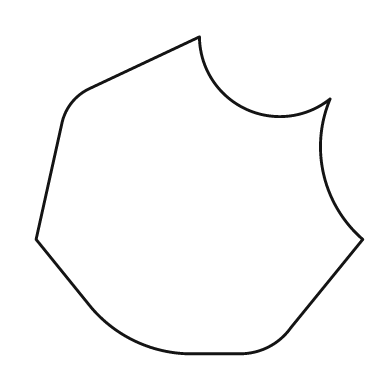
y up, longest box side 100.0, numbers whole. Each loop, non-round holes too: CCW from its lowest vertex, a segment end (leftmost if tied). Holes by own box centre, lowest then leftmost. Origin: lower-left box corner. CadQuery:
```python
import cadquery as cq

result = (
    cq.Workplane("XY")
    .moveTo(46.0, 0.0)
    .lineTo(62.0, 0.0)
    .threePointArc((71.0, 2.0), (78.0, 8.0))
    .lineTo(100.0, 35.0)
    .threePointArc((88.0, 55.0), (90.0, 78.0))
    .threePointArc((64.0, 75.0), (50.0, 97.0))
    .lineTo(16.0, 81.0)
    .threePointArc((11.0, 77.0), (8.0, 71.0))
    .lineTo(0.0, 35.0)
    .lineTo(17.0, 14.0)
    .threePointArc((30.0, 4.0), (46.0, 0.0))
    .close()
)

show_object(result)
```